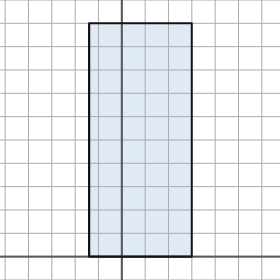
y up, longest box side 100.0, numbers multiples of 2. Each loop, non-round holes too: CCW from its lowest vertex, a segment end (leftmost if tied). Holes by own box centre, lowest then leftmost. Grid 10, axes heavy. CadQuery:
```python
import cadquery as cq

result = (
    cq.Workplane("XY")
    .moveTo(-14.0, 0.0)
    .lineTo(30.0, 0.0)
    .lineTo(30.0, 100.0)
    .lineTo(-14.0, 100.0)
    .close()
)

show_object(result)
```